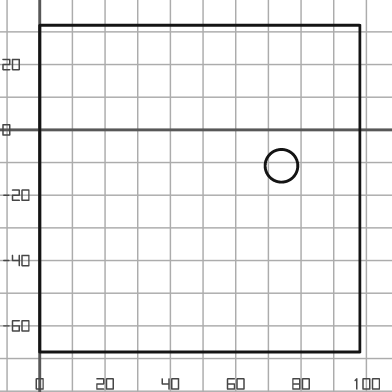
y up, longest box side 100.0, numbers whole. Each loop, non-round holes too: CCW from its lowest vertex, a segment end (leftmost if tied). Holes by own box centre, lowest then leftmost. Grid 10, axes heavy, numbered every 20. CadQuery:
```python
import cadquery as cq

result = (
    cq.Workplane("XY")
    .moveTo(0.0, -68.0)
    .lineTo(98.0, -68.0)
    .lineTo(98.0, 32.0)
    .lineTo(0.0, 32.0)
    .close()
    .moveTo(74.0, -11.0)
    .circle(5.0)
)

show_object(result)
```